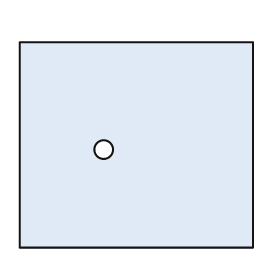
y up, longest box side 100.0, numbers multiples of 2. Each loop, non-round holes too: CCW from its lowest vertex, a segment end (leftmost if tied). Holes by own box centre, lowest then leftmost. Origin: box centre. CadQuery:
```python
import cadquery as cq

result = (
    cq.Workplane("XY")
    .moveTo(-50.0, -44.0)
    .lineTo(50.0, -44.0)
    .lineTo(50.0, 44.0)
    .lineTo(-50.0, 44.0)
    .close()
    .moveTo(-14.0, -2.0)
    .circle(4.0)
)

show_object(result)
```